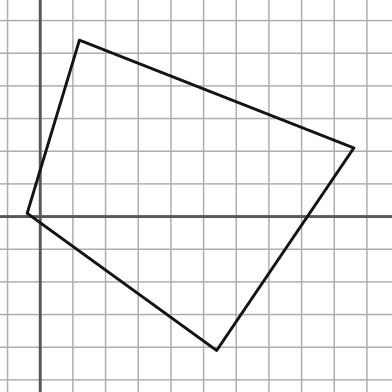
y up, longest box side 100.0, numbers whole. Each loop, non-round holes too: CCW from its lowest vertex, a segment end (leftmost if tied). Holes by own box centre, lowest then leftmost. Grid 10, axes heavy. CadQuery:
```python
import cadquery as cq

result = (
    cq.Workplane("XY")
    .moveTo(54.0, -41.0)
    .lineTo(96.0, 21.0)
    .lineTo(12.0, 54.0)
    .lineTo(-4.0, 1.0)
    .close()
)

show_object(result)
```